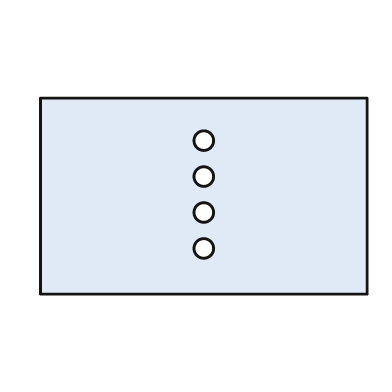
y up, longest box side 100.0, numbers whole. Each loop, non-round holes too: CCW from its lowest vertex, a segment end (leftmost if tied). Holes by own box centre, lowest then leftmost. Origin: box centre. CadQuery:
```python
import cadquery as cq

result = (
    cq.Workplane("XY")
    .moveTo(-50.0, -30.0)
    .lineTo(50.0, -30.0)
    .lineTo(50.0, 30.0)
    .lineTo(-50.0, 30.0)
    .close()
    .moveTo(0.0, -16.0)
    .circle(3.0)
    .moveTo(0.0, -5.0)
    .circle(3.0)
    .moveTo(0.0, 6.0)
    .circle(3.0)
    .moveTo(0.0, 17.0)
    .circle(3.0)
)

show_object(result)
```